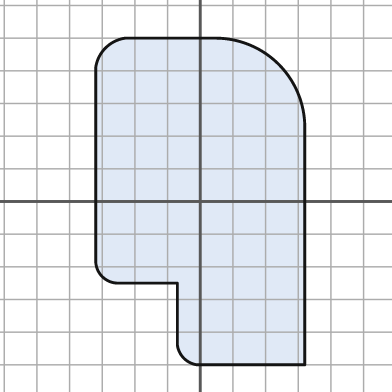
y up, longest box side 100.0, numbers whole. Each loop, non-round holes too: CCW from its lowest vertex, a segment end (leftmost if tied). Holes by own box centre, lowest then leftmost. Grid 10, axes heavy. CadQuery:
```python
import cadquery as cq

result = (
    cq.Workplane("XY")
    .moveTo(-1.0, -50.0)
    .lineTo(32.0, -50.0)
    .lineTo(32.0, 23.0)
    .threePointArc((24.0, 42.0), (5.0, 50.0))
    .lineTo(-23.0, 50.0)
    .threePointArc((-29.0, 47.0), (-32.0, 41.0))
    .lineTo(-32.0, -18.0)
    .threePointArc((-30.0, -23.0), (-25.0, -25.0))
    .lineTo(-7.0, -25.0)
    .lineTo(-7.0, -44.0)
    .threePointArc((-5.0, -48.0), (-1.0, -50.0))
    .close()
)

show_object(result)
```